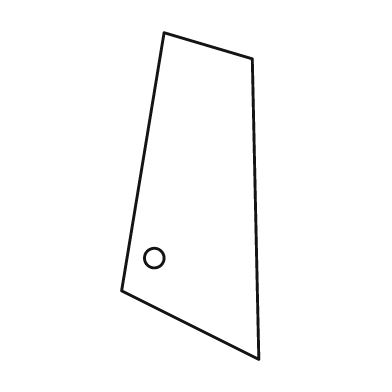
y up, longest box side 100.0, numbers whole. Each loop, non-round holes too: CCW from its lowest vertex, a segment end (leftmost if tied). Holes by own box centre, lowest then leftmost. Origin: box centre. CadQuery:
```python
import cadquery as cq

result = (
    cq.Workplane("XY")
    .moveTo(21.0, -50.0)
    .lineTo(19.0, 42.0)
    .lineTo(-8.0, 50.0)
    .lineTo(-21.0, -29.0)
    .close()
    .moveTo(-11.0, -19.0)
    .circle(3.0)
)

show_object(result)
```